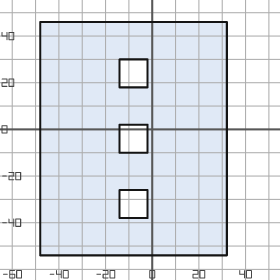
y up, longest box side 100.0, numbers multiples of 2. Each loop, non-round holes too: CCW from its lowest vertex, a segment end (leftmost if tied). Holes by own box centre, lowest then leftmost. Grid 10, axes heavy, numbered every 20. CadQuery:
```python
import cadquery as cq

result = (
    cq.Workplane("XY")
    .moveTo(-48.0, -54.0)
    .lineTo(32.0, -54.0)
    .lineTo(32.0, 46.0)
    .lineTo(-48.0, 46.0)
    .close()
    .moveTo(-14.0, -38.0)
    .lineTo(-2.0, -38.0)
    .lineTo(-2.0, -26.0)
    .lineTo(-14.0, -26.0)
    .close()
    .moveTo(-14.0, -10.0)
    .lineTo(-2.0, -10.0)
    .lineTo(-2.0, 2.0)
    .lineTo(-14.0, 2.0)
    .close()
    .moveTo(-14.0, 18.0)
    .lineTo(-2.0, 18.0)
    .lineTo(-2.0, 30.0)
    .lineTo(-14.0, 30.0)
    .close()
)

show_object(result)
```